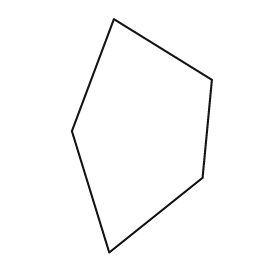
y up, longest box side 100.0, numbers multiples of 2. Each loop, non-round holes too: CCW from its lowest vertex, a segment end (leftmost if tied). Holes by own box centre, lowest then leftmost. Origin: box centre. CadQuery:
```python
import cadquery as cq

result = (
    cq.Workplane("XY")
    .moveTo(-14.0, -50.0)
    .lineTo(26.0, -18.0)
    .lineTo(30.0, 24.0)
    .lineTo(-12.0, 50.0)
    .lineTo(-30.0, 2.0)
    .close()
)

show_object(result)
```